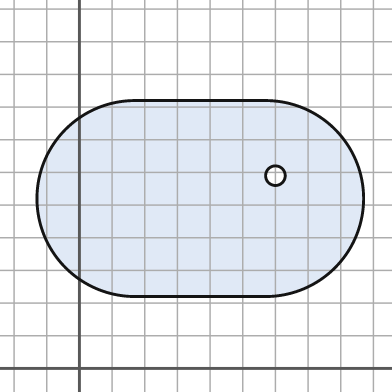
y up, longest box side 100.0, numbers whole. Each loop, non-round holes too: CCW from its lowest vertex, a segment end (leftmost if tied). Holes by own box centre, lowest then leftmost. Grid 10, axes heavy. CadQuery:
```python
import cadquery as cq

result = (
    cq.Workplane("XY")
    .moveTo(17.0, 22.0)
    .lineTo(57.0, 22.0)
    .threePointArc((87.0, 52.0), (57.0, 82.0))
    .lineTo(17.0, 82.0)
    .threePointArc((-13.0, 52.0), (17.0, 22.0))
    .close()
    .moveTo(60.0, 59.0)
    .circle(3.0)
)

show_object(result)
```